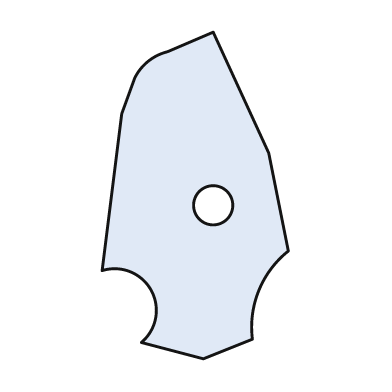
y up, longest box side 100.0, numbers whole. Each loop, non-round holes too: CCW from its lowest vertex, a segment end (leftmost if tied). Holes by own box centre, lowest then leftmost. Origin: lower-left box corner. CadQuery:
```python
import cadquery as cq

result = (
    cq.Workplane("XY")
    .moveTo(31.0, 0.0)
    .lineTo(46.0, 6.0)
    .threePointArc((48.0, 21.0), (57.0, 33.0))
    .lineTo(51.0, 63.0)
    .lineTo(34.0, 100.0)
    .lineTo(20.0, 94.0)
    .threePointArc((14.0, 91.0), (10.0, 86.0))
    .lineTo(6.0, 75.0)
    .lineTo(0.0, 27.0)
    .threePointArc((15.0, 21.0), (12.0, 5.0))
    .close()
    .moveTo(34.0, 47.0)
    .circle(6.0)
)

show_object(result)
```